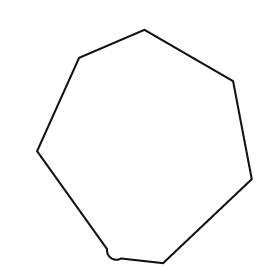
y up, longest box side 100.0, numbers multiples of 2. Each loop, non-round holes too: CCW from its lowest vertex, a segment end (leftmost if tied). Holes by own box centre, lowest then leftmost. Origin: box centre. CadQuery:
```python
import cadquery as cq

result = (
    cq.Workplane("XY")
    .moveTo(8.0, -50.0)
    .lineTo(46.0, -14.0)
    .lineTo(38.0, 28.0)
    .lineTo(0.0, 50.0)
    .lineTo(-28.0, 38.0)
    .lineTo(-46.0, -2.0)
    .lineTo(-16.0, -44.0)
    .threePointArc((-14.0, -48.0), (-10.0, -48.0))
    .close()
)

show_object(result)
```